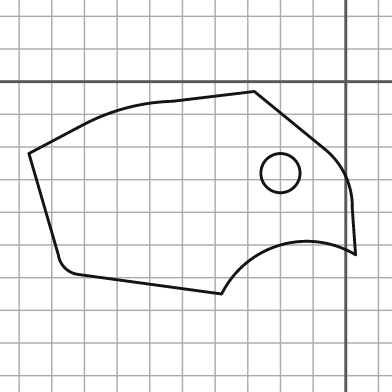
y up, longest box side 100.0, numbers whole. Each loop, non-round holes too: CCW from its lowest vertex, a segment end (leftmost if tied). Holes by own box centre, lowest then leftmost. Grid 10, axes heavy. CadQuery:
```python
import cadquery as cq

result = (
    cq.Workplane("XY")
    .moveTo(-38.0, -65.0)
    .threePointArc((-20.0, -50.0), (3.0, -53.0))
    .lineTo(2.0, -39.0)
    .threePointArc((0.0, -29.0), (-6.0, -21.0))
    .lineTo(-28.0, -3.0)
    .lineTo(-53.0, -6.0)
    .threePointArc((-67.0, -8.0), (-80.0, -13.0))
    .lineTo(-97.0, -22.0)
    .lineTo(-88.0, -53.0)
    .threePointArc((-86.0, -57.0), (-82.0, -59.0))
    .close()
    .moveTo(-20.0, -28.0)
    .circle(6.0)
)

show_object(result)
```